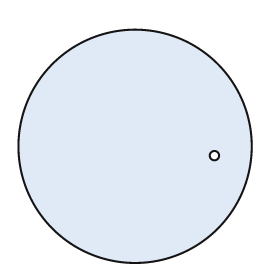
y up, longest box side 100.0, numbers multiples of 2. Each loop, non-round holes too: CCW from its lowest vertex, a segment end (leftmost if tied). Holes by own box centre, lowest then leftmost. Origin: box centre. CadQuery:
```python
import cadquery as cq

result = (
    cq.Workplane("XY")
    .moveTo(0.0, 0.0)
    .circle(50.0)
    .moveTo(34.0, -4.0)
    .circle(2.0)
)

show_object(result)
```